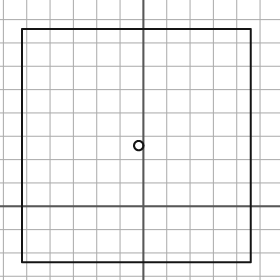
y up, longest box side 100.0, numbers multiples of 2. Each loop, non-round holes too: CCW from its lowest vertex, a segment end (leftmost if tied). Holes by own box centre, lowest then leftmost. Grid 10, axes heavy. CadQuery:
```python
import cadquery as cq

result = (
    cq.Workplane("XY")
    .moveTo(-52.0, -24.0)
    .lineTo(46.0, -24.0)
    .lineTo(46.0, 76.0)
    .lineTo(-52.0, 76.0)
    .close()
    .moveTo(-2.0, 26.0)
    .circle(2.0)
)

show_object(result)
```